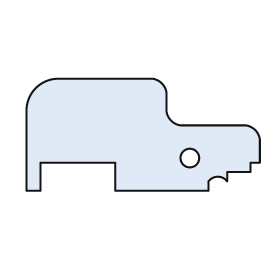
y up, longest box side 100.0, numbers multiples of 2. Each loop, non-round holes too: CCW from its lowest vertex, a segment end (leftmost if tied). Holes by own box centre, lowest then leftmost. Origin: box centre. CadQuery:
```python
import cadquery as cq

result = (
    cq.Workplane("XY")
    .moveTo(-50.0, -24.0)
    .lineTo(-44.0, -24.0)
    .lineTo(-44.0, -12.0)
    .lineTo(-12.0, -12.0)
    .lineTo(-12.0, -24.0)
    .lineTo(28.0, -24.0)
    .lineTo(28.0, -20.0)
    .threePointArc((32.0, -18.0), (36.0, -20.0))
    .lineTo(36.0, -16.0)
    .lineTo(46.0, -16.0)
    .lineTo(46.0, -12.0)
    .lineTo(50.0, -12.0)
    .lineTo(50.0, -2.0)
    .threePointArc((48.0, 2.0), (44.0, 4.0))
    .lineTo(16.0, 4.0)
    .threePointArc((12.0, 6.0), (10.0, 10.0))
    .lineTo(10.0, 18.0)
    .threePointArc((8.0, 22.0), (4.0, 24.0))
    .lineTo(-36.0, 24.0)
    .threePointArc((-46.0, 20.0), (-50.0, 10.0))
    .close()
    .moveTo(20.0, -10.0)
    .circle(4.0)
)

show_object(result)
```